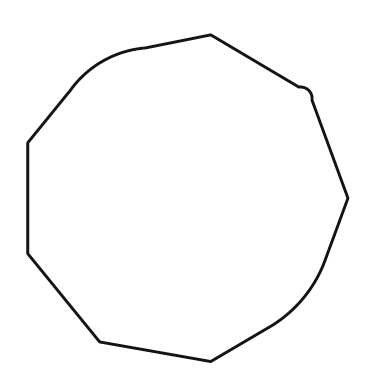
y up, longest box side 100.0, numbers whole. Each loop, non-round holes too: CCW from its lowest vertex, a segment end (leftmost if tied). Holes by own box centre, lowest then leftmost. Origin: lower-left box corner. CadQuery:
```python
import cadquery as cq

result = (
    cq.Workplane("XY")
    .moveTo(56.0, 0.0)
    .lineTo(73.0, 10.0)
    .threePointArc((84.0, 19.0), (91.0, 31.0))
    .lineTo(98.0, 50.0)
    .lineTo(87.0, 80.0)
    .threePointArc((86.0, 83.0), (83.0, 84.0))
    .lineTo(56.0, 100.0)
    .lineTo(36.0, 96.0)
    .threePointArc((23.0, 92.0), (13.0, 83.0))
    .lineTo(0.0, 67.0)
    .lineTo(0.0, 33.0)
    .lineTo(22.0, 6.0)
    .close()
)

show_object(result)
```